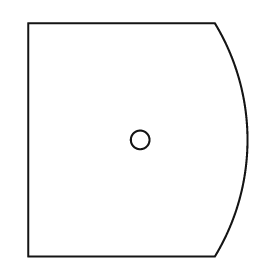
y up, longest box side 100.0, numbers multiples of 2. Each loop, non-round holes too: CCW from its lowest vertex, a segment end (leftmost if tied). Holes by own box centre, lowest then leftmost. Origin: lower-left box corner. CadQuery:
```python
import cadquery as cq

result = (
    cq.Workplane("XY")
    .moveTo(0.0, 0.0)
    .lineTo(80.0, 0.0)
    .threePointArc((94.0, 50.0), (80.0, 100.0))
    .lineTo(0.0, 100.0)
    .close()
    .moveTo(48.0, 50.0)
    .circle(4.0)
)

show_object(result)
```